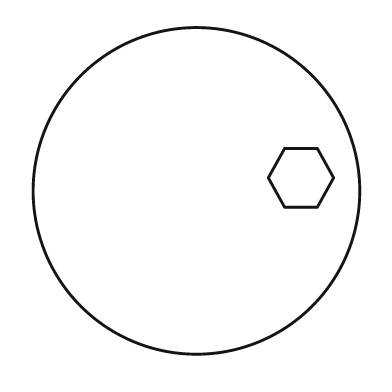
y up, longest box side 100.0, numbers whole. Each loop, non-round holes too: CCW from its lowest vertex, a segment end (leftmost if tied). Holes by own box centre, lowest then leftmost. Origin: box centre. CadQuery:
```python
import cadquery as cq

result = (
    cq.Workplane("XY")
    .moveTo(0.0, 0.0)
    .circle(50.0)
    .moveTo(27.0, -5.0)
    .lineTo(37.0, -5.0)
    .lineTo(42.0, 4.0)
    .lineTo(37.0, 13.0)
    .lineTo(27.0, 13.0)
    .lineTo(22.0, 4.0)
    .close()
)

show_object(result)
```